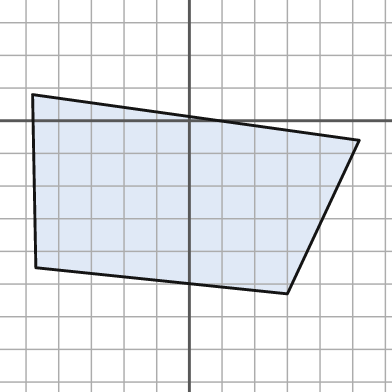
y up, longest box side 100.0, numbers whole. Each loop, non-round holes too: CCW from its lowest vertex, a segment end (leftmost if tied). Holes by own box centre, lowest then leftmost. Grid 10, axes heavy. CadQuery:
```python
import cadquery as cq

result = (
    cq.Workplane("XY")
    .moveTo(30.0, -53.0)
    .lineTo(52.0, -6.0)
    .lineTo(-48.0, 8.0)
    .lineTo(-47.0, -45.0)
    .close()
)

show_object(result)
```